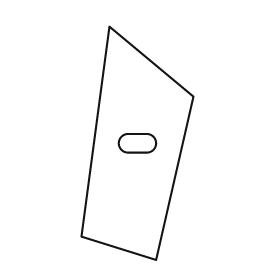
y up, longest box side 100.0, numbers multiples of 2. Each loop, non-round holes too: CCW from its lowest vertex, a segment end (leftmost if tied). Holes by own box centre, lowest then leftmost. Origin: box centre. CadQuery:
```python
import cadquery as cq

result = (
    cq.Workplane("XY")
    .moveTo(8.0, -50.0)
    .lineTo(24.0, 20.0)
    .lineTo(-12.0, 50.0)
    .lineTo(-24.0, -40.0)
    .close()
    .moveTo(-4.0, -4.0)
    .lineTo(4.0, -4.0)
    .threePointArc((8.0, 0.0), (4.0, 4.0))
    .lineTo(-4.0, 4.0)
    .threePointArc((-8.0, 0.0), (-4.0, -4.0))
    .close()
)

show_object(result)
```